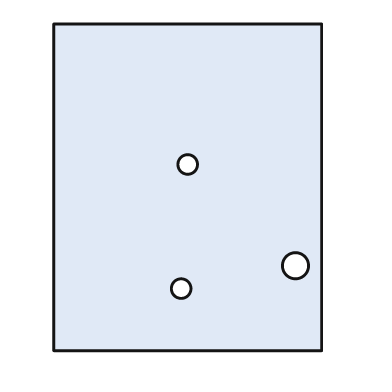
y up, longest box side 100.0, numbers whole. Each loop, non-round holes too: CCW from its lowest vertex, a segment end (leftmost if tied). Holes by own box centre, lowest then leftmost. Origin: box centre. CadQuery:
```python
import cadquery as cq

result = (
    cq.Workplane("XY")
    .moveTo(-41.0, -50.0)
    .lineTo(41.0, -50.0)
    .lineTo(41.0, 50.0)
    .lineTo(-41.0, 50.0)
    .close()
    .moveTo(-2.0, -31.0)
    .circle(3.0)
    .moveTo(33.0, -24.0)
    .circle(4.0)
    .moveTo(0.0, 7.0)
    .circle(3.0)
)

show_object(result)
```